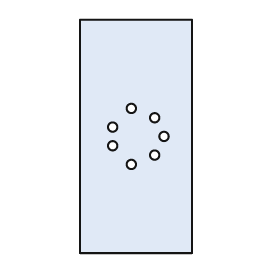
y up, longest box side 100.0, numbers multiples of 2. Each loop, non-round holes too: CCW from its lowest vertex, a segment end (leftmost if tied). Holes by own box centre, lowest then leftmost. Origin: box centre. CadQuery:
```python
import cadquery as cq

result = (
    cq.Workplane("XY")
    .moveTo(-24.0, -50.0)
    .lineTo(24.0, -50.0)
    .lineTo(24.0, 50.0)
    .lineTo(-24.0, 50.0)
    .close()
    .moveTo(-2.0, -12.0)
    .circle(2.0)
    .moveTo(8.0, -8.0)
    .circle(2.0)
    .moveTo(-10.0, -4.0)
    .circle(2.0)
    .moveTo(12.0, 0.0)
    .circle(2.0)
    .moveTo(-10.0, 4.0)
    .circle(2.0)
    .moveTo(8.0, 8.0)
    .circle(2.0)
    .moveTo(-2.0, 12.0)
    .circle(2.0)
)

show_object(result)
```